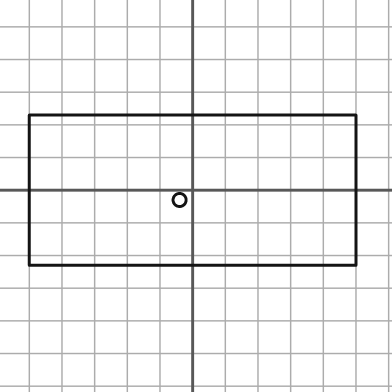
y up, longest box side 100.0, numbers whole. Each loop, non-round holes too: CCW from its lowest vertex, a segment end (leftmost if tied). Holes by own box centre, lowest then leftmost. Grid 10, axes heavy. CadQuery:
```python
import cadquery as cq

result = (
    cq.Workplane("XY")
    .moveTo(-50.0, -23.0)
    .lineTo(50.0, -23.0)
    .lineTo(50.0, 23.0)
    .lineTo(-50.0, 23.0)
    .close()
    .moveTo(-4.0, -3.0)
    .circle(2.0)
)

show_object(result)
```